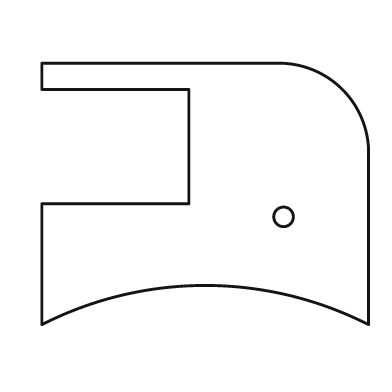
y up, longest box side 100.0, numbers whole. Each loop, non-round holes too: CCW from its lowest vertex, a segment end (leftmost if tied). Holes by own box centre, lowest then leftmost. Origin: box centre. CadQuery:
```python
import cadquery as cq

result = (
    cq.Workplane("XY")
    .moveTo(-50.0, -40.0)
    .threePointArc((0.0, -28.0), (50.0, -40.0))
    .lineTo(50.0, 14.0)
    .threePointArc((42.0, 32.0), (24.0, 40.0))
    .lineTo(-50.0, 40.0)
    .lineTo(-50.0, 32.0)
    .lineTo(-5.0, 32.0)
    .lineTo(-5.0, -3.0)
    .lineTo(-50.0, -3.0)
    .close()
    .moveTo(24.0, -7.0)
    .circle(3.0)
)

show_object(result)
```